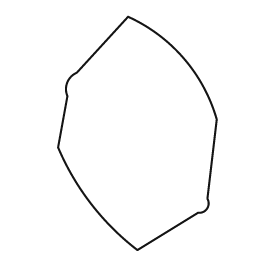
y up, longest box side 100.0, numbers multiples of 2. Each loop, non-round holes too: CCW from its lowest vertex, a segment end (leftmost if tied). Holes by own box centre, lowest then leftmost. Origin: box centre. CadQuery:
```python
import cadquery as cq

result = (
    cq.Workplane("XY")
    .moveTo(0.0, -50.0)
    .lineTo(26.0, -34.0)
    .threePointArc((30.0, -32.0), (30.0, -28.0))
    .lineTo(34.0, 6.0)
    .threePointArc((20.0, 32.0), (-4.0, 50.0))
    .lineTo(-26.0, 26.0)
    .threePointArc((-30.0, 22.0), (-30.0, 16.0))
    .lineTo(-34.0, -6.0)
    .threePointArc((-20.0, -30.0), (0.0, -50.0))
    .close()
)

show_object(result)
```